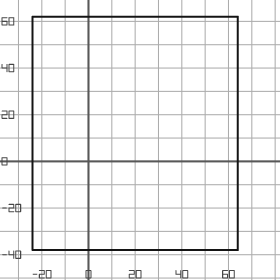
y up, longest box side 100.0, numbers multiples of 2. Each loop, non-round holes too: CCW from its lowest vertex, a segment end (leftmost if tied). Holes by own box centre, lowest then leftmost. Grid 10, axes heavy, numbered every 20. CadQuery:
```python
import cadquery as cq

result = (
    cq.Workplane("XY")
    .moveTo(-24.0, -38.0)
    .lineTo(64.0, -38.0)
    .lineTo(64.0, 62.0)
    .lineTo(-24.0, 62.0)
    .close()
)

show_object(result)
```